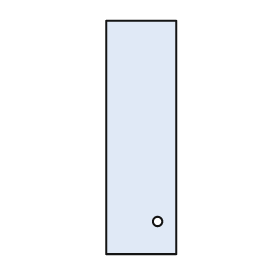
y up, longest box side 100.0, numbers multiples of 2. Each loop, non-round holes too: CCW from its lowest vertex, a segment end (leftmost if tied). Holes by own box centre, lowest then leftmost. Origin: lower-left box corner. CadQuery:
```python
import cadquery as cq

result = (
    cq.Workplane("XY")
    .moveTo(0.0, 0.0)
    .lineTo(30.0, 0.0)
    .lineTo(30.0, 100.0)
    .lineTo(0.0, 100.0)
    .close()
    .moveTo(22.0, 14.0)
    .circle(2.0)
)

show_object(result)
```